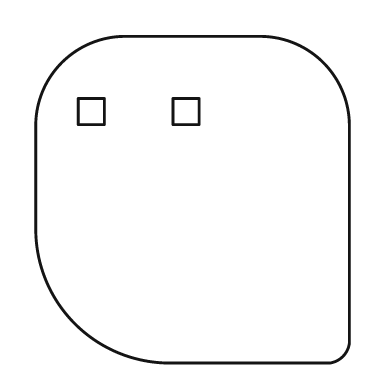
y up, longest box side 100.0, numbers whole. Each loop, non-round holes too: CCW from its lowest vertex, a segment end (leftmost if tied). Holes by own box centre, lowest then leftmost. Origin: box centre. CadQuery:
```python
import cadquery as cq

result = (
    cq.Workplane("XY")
    .moveTo(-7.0, -50.0)
    .lineTo(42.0, -50.0)
    .threePointArc((46.0, -48.0), (48.0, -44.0))
    .lineTo(48.0, 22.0)
    .threePointArc((40.0, 42.0), (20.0, 50.0))
    .lineTo(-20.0, 50.0)
    .threePointArc((-40.0, 42.0), (-48.0, 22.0))
    .lineTo(-48.0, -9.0)
    .threePointArc((-36.0, -38.0), (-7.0, -50.0))
    .close()
    .moveTo(-35.0, 23.0)
    .lineTo(-27.0, 23.0)
    .lineTo(-27.0, 31.0)
    .lineTo(-35.0, 31.0)
    .close()
    .moveTo(-6.0, 23.0)
    .lineTo(2.0, 23.0)
    .lineTo(2.0, 31.0)
    .lineTo(-6.0, 31.0)
    .close()
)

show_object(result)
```